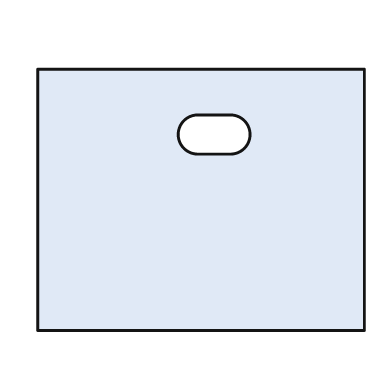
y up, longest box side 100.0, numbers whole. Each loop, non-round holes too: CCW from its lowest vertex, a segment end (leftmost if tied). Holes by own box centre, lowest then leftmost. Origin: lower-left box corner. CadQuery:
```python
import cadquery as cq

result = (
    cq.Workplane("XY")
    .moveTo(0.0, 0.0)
    .lineTo(100.0, 0.0)
    .lineTo(100.0, 80.0)
    .lineTo(0.0, 80.0)
    .close()
    .moveTo(49.0, 54.0)
    .lineTo(59.0, 54.0)
    .threePointArc((65.0, 60.0), (59.0, 66.0))
    .lineTo(49.0, 66.0)
    .threePointArc((43.0, 60.0), (49.0, 54.0))
    .close()
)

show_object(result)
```